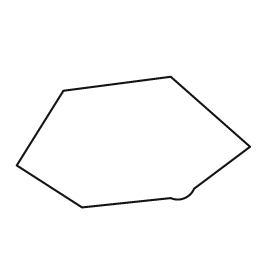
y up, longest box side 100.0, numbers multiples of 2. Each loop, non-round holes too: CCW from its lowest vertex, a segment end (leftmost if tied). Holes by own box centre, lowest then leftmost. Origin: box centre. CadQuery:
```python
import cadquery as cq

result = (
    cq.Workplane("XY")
    .moveTo(-22.0, -28.0)
    .lineTo(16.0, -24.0)
    .threePointArc((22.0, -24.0), (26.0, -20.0))
    .lineTo(50.0, -2.0)
    .lineTo(16.0, 28.0)
    .lineTo(-30.0, 22.0)
    .lineTo(-50.0, -10.0)
    .close()
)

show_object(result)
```